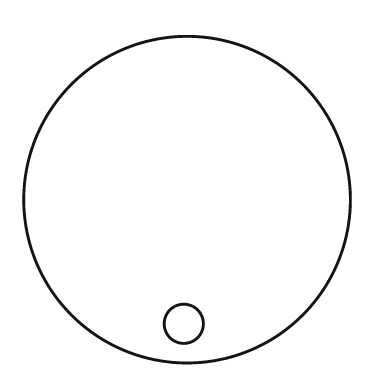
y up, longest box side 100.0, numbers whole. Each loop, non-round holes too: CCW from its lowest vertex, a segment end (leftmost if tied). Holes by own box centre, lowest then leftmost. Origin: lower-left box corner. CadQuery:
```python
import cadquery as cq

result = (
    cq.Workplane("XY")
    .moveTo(50.0, 50.0)
    .circle(50.0)
    .moveTo(49.0, 12.0)
    .circle(6.0)
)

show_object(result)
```